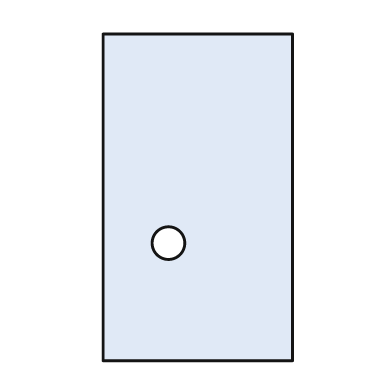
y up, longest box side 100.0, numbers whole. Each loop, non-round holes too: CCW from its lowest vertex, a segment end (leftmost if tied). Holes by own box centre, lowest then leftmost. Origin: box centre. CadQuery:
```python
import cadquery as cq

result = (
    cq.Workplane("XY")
    .moveTo(-29.0, -50.0)
    .lineTo(29.0, -50.0)
    .lineTo(29.0, 50.0)
    .lineTo(-29.0, 50.0)
    .close()
    .moveTo(-9.0, -14.0)
    .circle(5.0)
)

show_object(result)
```